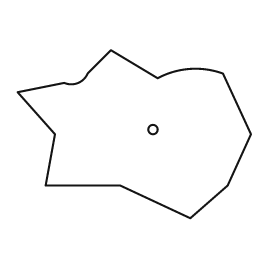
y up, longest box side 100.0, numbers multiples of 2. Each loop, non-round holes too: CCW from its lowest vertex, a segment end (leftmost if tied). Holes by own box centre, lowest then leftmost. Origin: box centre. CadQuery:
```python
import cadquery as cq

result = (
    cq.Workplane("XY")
    .moveTo(24.0, -36.0)
    .lineTo(40.0, -22.0)
    .lineTo(50.0, 0.0)
    .lineTo(38.0, 26.0)
    .threePointArc((24.0, 28.0), (10.0, 24.0))
    .lineTo(-10.0, 36.0)
    .lineTo(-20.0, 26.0)
    .threePointArc((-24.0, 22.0), (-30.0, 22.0))
    .lineTo(-50.0, 18.0)
    .lineTo(-34.0, 0.0)
    .lineTo(-38.0, -22.0)
    .lineTo(-6.0, -22.0)
    .close()
    .moveTo(8.0, 2.0)
    .circle(2.0)
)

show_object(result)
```